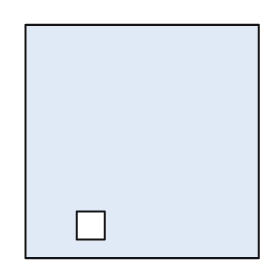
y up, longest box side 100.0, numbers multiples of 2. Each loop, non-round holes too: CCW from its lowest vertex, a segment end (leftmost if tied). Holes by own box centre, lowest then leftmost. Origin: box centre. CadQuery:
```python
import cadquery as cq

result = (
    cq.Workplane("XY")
    .moveTo(-50.0, -50.0)
    .lineTo(50.0, -50.0)
    .lineTo(50.0, 50.0)
    .lineTo(-50.0, 50.0)
    .close()
    .moveTo(-28.0, -42.0)
    .lineTo(-16.0, -42.0)
    .lineTo(-16.0, -30.0)
    .lineTo(-28.0, -30.0)
    .close()
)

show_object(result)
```